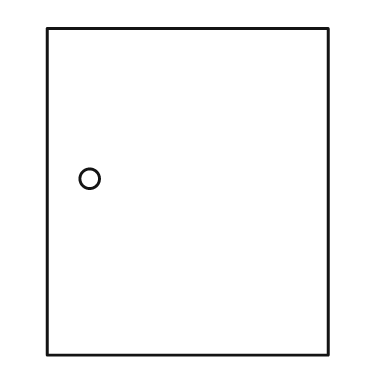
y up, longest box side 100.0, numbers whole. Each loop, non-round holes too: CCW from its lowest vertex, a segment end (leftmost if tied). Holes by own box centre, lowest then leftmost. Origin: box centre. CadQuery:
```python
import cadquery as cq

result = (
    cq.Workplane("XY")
    .moveTo(-43.0, -50.0)
    .lineTo(43.0, -50.0)
    .lineTo(43.0, 50.0)
    .lineTo(-43.0, 50.0)
    .close()
    .moveTo(-30.0, 4.0)
    .circle(3.0)
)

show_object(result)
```